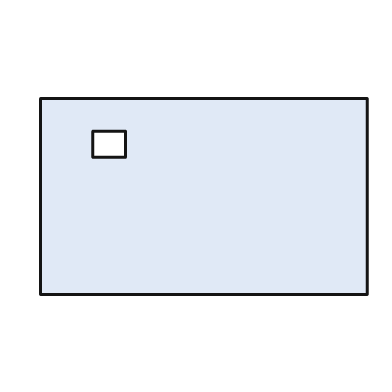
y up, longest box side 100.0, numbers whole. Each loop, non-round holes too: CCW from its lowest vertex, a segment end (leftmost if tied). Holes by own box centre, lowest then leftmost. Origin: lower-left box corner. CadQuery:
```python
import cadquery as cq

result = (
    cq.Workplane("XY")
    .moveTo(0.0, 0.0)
    .lineTo(100.0, 0.0)
    .lineTo(100.0, 60.0)
    .lineTo(0.0, 60.0)
    .close()
    .moveTo(16.0, 42.0)
    .lineTo(26.0, 42.0)
    .lineTo(26.0, 50.0)
    .lineTo(16.0, 50.0)
    .close()
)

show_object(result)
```